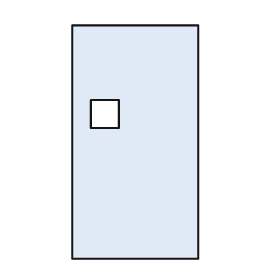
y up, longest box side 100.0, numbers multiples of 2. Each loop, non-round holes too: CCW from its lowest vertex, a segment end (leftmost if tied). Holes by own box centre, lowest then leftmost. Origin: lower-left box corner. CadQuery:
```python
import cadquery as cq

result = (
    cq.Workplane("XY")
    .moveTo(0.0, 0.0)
    .lineTo(54.0, 0.0)
    .lineTo(54.0, 100.0)
    .lineTo(0.0, 100.0)
    .close()
    .moveTo(8.0, 56.0)
    .lineTo(20.0, 56.0)
    .lineTo(20.0, 68.0)
    .lineTo(8.0, 68.0)
    .close()
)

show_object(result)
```